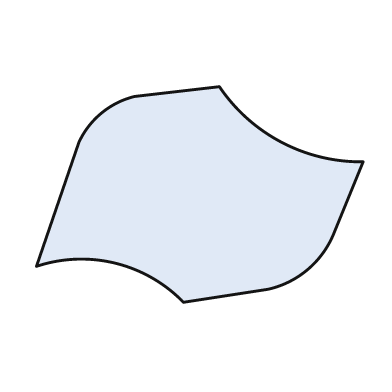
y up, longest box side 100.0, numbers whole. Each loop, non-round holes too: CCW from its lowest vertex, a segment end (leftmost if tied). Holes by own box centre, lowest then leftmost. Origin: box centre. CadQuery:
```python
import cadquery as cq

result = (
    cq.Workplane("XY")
    .moveTo(-5.0, -33.0)
    .lineTo(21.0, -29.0)
    .threePointArc((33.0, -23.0), (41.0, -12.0))
    .lineTo(50.0, 10.0)
    .threePointArc((25.0, 16.0), (6.0, 33.0))
    .lineTo(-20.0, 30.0)
    .threePointArc((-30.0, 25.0), (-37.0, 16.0))
    .lineTo(-50.0, -22.0)
    .threePointArc((-26.0, -21.0), (-5.0, -33.0))
    .close()
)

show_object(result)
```